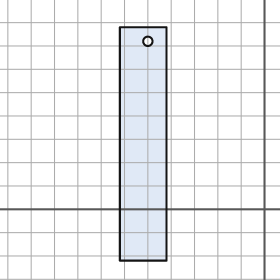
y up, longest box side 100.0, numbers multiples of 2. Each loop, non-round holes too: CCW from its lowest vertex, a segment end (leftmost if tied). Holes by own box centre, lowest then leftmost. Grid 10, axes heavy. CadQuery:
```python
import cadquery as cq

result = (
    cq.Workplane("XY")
    .moveTo(-62.0, -22.0)
    .lineTo(-42.0, -22.0)
    .lineTo(-42.0, 78.0)
    .lineTo(-62.0, 78.0)
    .close()
    .moveTo(-50.0, 72.0)
    .circle(2.0)
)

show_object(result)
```